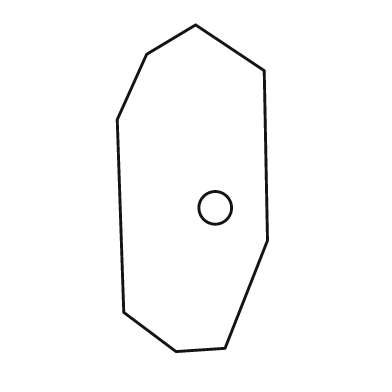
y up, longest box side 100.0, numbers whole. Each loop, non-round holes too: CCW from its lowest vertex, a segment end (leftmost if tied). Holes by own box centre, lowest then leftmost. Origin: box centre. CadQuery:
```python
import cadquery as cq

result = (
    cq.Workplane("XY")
    .moveTo(-5.0, -50.0)
    .lineTo(10.0, -49.0)
    .lineTo(23.0, -16.0)
    .lineTo(22.0, 36.0)
    .lineTo(1.0, 50.0)
    .lineTo(-14.0, 41.0)
    .lineTo(-23.0, 21.0)
    .lineTo(-21.0, -38.0)
    .close()
    .moveTo(7.0, -6.0)
    .circle(5.0)
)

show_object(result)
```